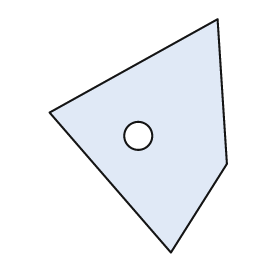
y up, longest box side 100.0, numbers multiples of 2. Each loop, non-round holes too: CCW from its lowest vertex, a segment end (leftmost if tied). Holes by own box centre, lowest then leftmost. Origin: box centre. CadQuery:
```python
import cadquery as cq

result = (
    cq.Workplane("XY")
    .moveTo(14.0, -50.0)
    .lineTo(38.0, -12.0)
    .lineTo(34.0, 50.0)
    .lineTo(-38.0, 10.0)
    .close()
    .moveTo(0.0, 0.0)
    .circle(6.0)
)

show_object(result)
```